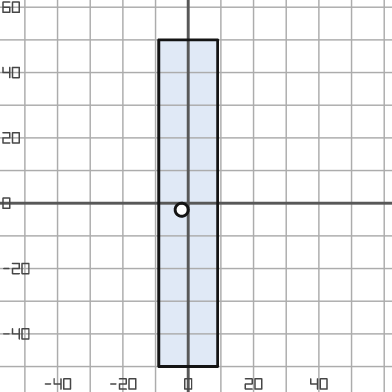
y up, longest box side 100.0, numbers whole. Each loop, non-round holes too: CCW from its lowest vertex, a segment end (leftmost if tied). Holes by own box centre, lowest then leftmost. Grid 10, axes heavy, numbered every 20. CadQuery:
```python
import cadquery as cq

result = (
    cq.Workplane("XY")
    .moveTo(-9.0, -50.0)
    .lineTo(9.0, -50.0)
    .lineTo(9.0, 50.0)
    .lineTo(-9.0, 50.0)
    .close()
    .moveTo(-2.0, -2.0)
    .circle(2.0)
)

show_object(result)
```